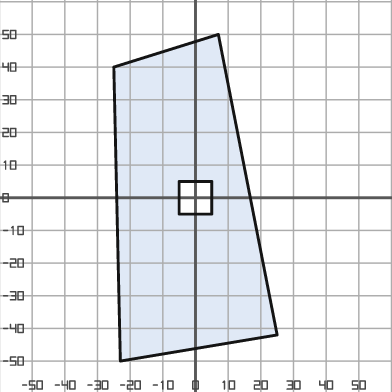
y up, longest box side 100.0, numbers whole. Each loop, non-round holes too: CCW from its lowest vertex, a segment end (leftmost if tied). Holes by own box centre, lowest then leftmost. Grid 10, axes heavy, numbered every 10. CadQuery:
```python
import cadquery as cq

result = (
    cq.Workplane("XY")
    .moveTo(-23.0, -50.0)
    .lineTo(25.0, -42.0)
    .lineTo(7.0, 50.0)
    .lineTo(-25.0, 40.0)
    .close()
    .moveTo(-5.0, -5.0)
    .lineTo(5.0, -5.0)
    .lineTo(5.0, 5.0)
    .lineTo(-5.0, 5.0)
    .close()
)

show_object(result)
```